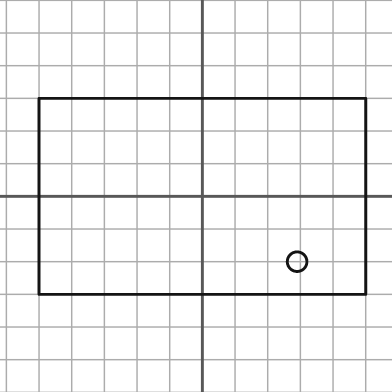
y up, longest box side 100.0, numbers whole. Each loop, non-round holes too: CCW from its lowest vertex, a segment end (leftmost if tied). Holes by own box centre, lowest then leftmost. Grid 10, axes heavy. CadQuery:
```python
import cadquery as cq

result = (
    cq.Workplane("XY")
    .moveTo(-50.0, -30.0)
    .lineTo(50.0, -30.0)
    .lineTo(50.0, 30.0)
    .lineTo(-50.0, 30.0)
    .close()
    .moveTo(29.0, -20.0)
    .circle(3.0)
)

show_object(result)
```